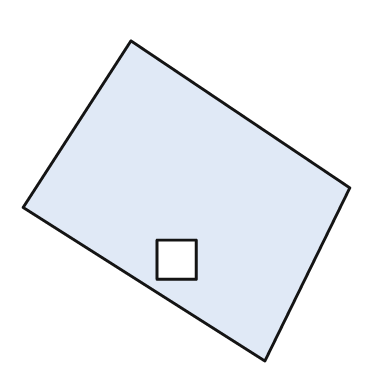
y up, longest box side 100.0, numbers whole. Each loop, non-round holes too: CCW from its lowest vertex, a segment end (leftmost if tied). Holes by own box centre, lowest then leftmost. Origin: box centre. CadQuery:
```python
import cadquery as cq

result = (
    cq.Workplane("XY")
    .moveTo(24.0, -49.0)
    .lineTo(50.0, 4.0)
    .lineTo(-17.0, 49.0)
    .lineTo(-50.0, -2.0)
    .close()
    .moveTo(-9.0, -24.0)
    .lineTo(3.0, -24.0)
    .lineTo(3.0, -12.0)
    .lineTo(-9.0, -12.0)
    .close()
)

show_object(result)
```